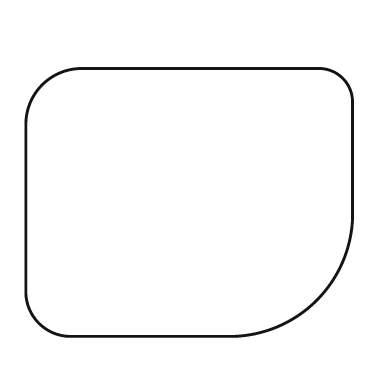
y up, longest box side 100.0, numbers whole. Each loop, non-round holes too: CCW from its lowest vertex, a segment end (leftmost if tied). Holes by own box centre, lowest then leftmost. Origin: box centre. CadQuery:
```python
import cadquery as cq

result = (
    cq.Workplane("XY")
    .moveTo(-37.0, -41.0)
    .lineTo(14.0, -41.0)
    .threePointArc((39.0, -30.0), (50.0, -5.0))
    .lineTo(50.0, 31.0)
    .threePointArc((47.0, 38.0), (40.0, 41.0))
    .lineTo(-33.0, 41.0)
    .threePointArc((-45.0, 36.0), (-50.0, 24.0))
    .lineTo(-50.0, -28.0)
    .threePointArc((-46.0, -37.0), (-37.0, -41.0))
    .close()
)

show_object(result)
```